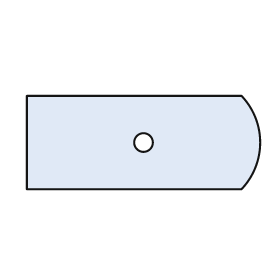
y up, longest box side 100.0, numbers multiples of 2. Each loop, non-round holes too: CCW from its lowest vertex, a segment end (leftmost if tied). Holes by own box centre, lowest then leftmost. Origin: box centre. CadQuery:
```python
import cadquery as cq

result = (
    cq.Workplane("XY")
    .moveTo(-50.0, -20.0)
    .lineTo(42.0, -20.0)
    .threePointArc((50.0, 0.0), (42.0, 20.0))
    .lineTo(-50.0, 20.0)
    .close()
    .moveTo(0.0, 0.0)
    .circle(4.0)
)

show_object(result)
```